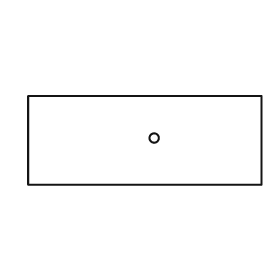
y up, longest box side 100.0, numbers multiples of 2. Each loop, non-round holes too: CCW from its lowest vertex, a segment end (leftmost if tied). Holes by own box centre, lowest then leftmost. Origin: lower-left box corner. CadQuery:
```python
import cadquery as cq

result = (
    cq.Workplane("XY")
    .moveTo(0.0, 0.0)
    .lineTo(100.0, 0.0)
    .lineTo(100.0, 38.0)
    .lineTo(0.0, 38.0)
    .close()
    .moveTo(54.0, 20.0)
    .circle(2.0)
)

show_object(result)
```